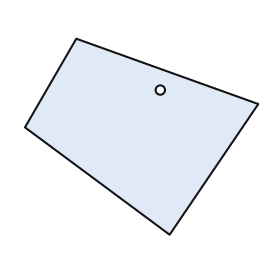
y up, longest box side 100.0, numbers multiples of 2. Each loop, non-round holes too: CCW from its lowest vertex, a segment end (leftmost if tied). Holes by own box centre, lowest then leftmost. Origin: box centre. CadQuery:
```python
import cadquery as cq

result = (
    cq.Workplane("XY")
    .moveTo(12.0, -42.0)
    .lineTo(50.0, 14.0)
    .lineTo(-28.0, 42.0)
    .lineTo(-50.0, 4.0)
    .close()
    .moveTo(8.0, 20.0)
    .circle(2.0)
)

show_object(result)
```